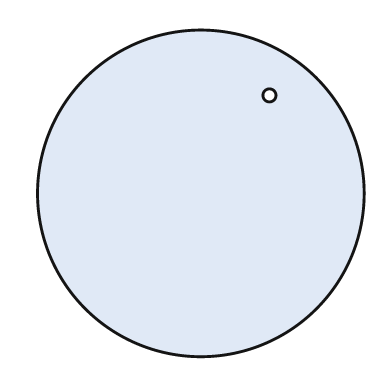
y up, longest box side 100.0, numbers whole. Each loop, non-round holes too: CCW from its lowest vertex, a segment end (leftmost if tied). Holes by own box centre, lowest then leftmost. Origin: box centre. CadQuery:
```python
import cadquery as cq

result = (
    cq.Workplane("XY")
    .moveTo(0.0, 0.0)
    .circle(50.0)
    .moveTo(21.0, 30.0)
    .circle(2.0)
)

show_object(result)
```